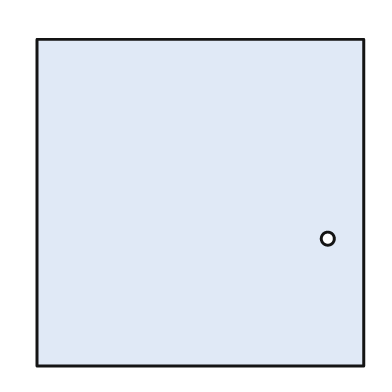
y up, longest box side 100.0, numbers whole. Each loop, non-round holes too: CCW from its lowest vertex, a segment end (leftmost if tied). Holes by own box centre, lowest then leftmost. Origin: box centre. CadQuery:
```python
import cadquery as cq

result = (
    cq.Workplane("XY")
    .moveTo(-50.0, -50.0)
    .lineTo(50.0, -50.0)
    .lineTo(50.0, 50.0)
    .lineTo(-50.0, 50.0)
    .close()
    .moveTo(39.0, -11.0)
    .circle(2.0)
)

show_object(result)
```